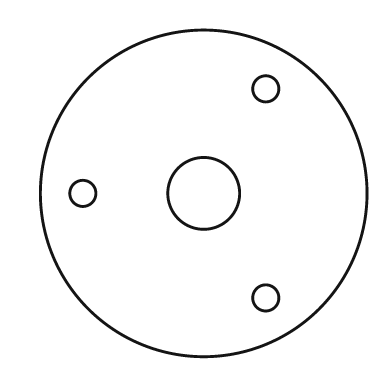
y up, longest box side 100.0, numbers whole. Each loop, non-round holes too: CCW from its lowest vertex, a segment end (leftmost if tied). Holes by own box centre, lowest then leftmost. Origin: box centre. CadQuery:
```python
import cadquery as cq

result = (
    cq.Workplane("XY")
    .moveTo(0.0, 0.0)
    .circle(50.0)
    .moveTo(19.0, -32.0)
    .circle(4.0)
    .moveTo(-37.0, 0.0)
    .circle(4.0)
    .moveTo(0.0, 0.0)
    .circle(11.0)
    .moveTo(19.0, 32.0)
    .circle(4.0)
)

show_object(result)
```